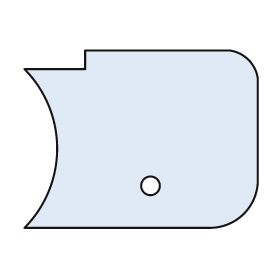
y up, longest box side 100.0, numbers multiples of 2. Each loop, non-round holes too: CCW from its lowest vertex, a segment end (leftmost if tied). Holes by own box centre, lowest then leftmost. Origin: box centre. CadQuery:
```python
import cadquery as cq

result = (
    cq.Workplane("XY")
    .moveTo(-50.0, -38.0)
    .lineTo(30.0, -38.0)
    .threePointArc((44.0, -32.0), (50.0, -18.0))
    .lineTo(50.0, 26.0)
    .threePointArc((46.0, 34.0), (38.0, 38.0))
    .lineTo(-24.0, 38.0)
    .lineTo(-24.0, 30.0)
    .lineTo(-50.0, 30.0)
    .threePointArc((-36.0, -4.0), (-50.0, -38.0))
    .close()
    .moveTo(4.0, -20.0)
    .circle(4.0)
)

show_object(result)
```